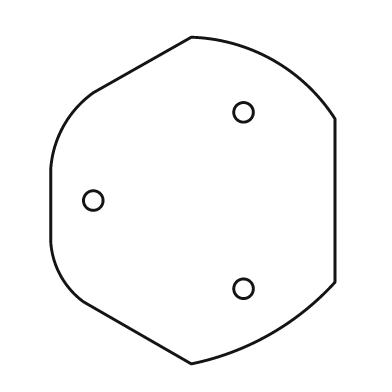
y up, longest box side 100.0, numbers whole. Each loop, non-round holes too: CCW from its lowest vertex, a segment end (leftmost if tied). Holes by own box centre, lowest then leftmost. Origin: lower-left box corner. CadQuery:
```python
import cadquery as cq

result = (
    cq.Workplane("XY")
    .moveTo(43.0, 0.0)
    .threePointArc((67.0, 9.0), (87.0, 25.0))
    .lineTo(87.0, 75.0)
    .threePointArc((68.0, 93.0), (43.0, 100.0))
    .lineTo(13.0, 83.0)
    .threePointArc((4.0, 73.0), (0.0, 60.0))
    .lineTo(0.0, 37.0)
    .threePointArc((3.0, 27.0), (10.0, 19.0))
    .close()
    .moveTo(59.0, 23.0)
    .circle(3.0)
    .moveTo(13.0, 50.0)
    .circle(3.0)
    .moveTo(59.0, 77.0)
    .circle(3.0)
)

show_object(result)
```